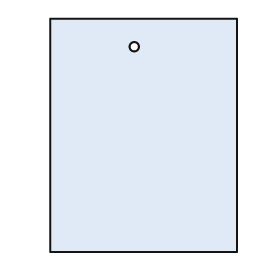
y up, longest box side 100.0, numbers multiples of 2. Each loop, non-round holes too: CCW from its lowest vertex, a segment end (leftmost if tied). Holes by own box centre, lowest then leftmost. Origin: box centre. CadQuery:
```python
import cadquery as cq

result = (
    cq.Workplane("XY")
    .moveTo(-40.0, -50.0)
    .lineTo(40.0, -50.0)
    .lineTo(40.0, 50.0)
    .lineTo(-40.0, 50.0)
    .close()
    .moveTo(-4.0, 38.0)
    .circle(2.0)
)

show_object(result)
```